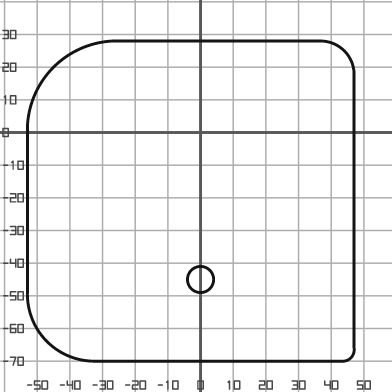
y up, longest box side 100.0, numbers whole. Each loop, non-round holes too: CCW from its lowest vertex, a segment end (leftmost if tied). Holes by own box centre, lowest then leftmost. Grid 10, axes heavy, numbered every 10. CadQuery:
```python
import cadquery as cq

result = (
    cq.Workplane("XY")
    .moveTo(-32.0, -70.0)
    .lineTo(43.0, -70.0)
    .threePointArc((46.0, -69.0), (47.0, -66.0))
    .lineTo(47.0, 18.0)
    .threePointArc((44.0, 25.0), (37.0, 28.0))
    .lineTo(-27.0, 28.0)
    .threePointArc((-45.0, 20.0), (-53.0, 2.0))
    .lineTo(-53.0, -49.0)
    .threePointArc((-47.0, -64.0), (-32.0, -70.0))
    .close()
    .moveTo(0.0, -45.0)
    .circle(4.0)
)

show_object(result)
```